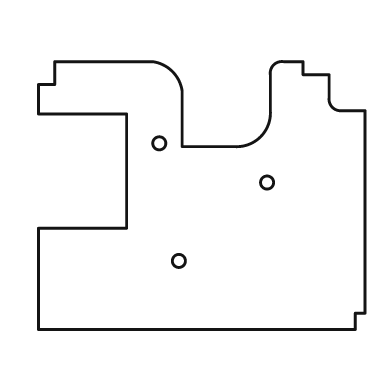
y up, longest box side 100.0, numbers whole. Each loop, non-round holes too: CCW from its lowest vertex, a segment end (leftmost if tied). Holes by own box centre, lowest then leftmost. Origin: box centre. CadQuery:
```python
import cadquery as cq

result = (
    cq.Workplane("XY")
    .moveTo(-50.0, -41.0)
    .lineTo(47.0, -41.0)
    .lineTo(47.0, -36.0)
    .lineTo(50.0, -36.0)
    .lineTo(50.0, 26.0)
    .lineTo(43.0, 26.0)
    .threePointArc((40.0, 27.0), (39.0, 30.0))
    .lineTo(39.0, 37.0)
    .lineTo(31.0, 37.0)
    .lineTo(31.0, 41.0)
    .lineTo(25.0, 41.0)
    .threePointArc((22.0, 40.0), (21.0, 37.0))
    .lineTo(21.0, 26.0)
    .threePointArc((18.0, 18.0), (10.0, 15.0))
    .lineTo(-6.0, 15.0)
    .lineTo(-6.0, 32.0)
    .threePointArc((-9.0, 38.0), (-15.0, 41.0))
    .lineTo(-45.0, 41.0)
    .lineTo(-45.0, 34.0)
    .lineTo(-50.0, 34.0)
    .lineTo(-50.0, 25.0)
    .lineTo(-23.0, 25.0)
    .lineTo(-23.0, -10.0)
    .lineTo(-50.0, -10.0)
    .close()
    .moveTo(-7.0, -20.0)
    .circle(2.0)
    .moveTo(20.0, 4.0)
    .circle(2.0)
    .moveTo(-13.0, 16.0)
    .circle(2.0)
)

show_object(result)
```